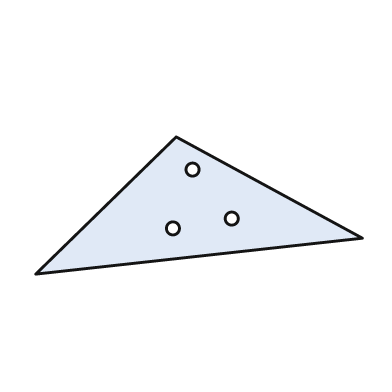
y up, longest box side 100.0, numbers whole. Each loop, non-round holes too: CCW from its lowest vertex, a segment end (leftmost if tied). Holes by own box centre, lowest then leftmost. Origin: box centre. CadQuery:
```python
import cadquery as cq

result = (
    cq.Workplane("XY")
    .moveTo(-50.0, -21.0)
    .lineTo(50.0, -10.0)
    .lineTo(-7.0, 21.0)
    .close()
    .moveTo(-8.0, -7.0)
    .circle(2.0)
    .moveTo(10.0, -4.0)
    .circle(2.0)
    .moveTo(-2.0, 11.0)
    .circle(2.0)
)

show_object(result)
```